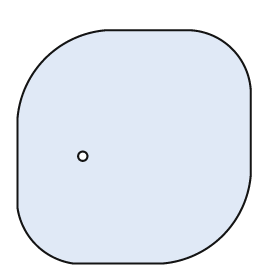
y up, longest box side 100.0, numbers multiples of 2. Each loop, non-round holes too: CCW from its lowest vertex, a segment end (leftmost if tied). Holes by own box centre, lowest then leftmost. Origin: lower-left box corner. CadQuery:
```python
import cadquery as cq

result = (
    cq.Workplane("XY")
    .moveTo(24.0, 0.0)
    .lineTo(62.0, 0.0)
    .threePointArc((88.0, 12.0), (100.0, 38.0))
    .lineTo(100.0, 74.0)
    .threePointArc((92.0, 92.0), (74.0, 100.0))
    .lineTo(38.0, 100.0)
    .threePointArc((12.0, 88.0), (0.0, 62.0))
    .lineTo(0.0, 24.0)
    .threePointArc((8.0, 8.0), (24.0, 0.0))
    .close()
    .moveTo(28.0, 46.0)
    .circle(2.0)
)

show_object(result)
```